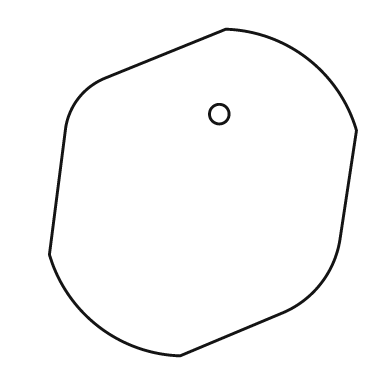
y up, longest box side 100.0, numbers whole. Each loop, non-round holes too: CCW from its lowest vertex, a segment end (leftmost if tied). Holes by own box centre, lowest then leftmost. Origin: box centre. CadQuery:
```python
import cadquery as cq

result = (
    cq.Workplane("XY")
    .moveTo(-7.0, -50.0)
    .lineTo(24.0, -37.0)
    .threePointArc((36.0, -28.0), (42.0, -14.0))
    .lineTo(47.0, 19.0)
    .threePointArc((32.0, 41.0), (7.0, 50.0))
    .lineTo(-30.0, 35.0)
    .threePointArc((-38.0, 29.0), (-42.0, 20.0))
    .lineTo(-47.0, -19.0)
    .threePointArc((-32.0, -41.0), (-7.0, -50.0))
    .close()
    .moveTo(5.0, 24.0)
    .circle(3.0)
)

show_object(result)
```